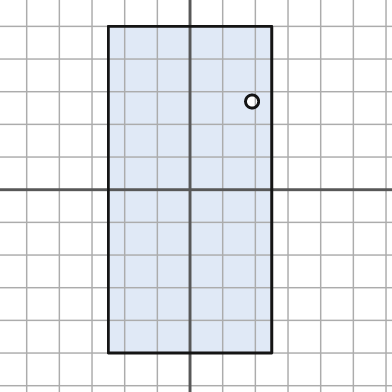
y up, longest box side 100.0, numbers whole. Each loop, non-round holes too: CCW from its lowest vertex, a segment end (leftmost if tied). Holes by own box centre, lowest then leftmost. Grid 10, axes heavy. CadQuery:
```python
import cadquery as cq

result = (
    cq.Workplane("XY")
    .moveTo(-25.0, -50.0)
    .lineTo(25.0, -50.0)
    .lineTo(25.0, 50.0)
    .lineTo(-25.0, 50.0)
    .close()
    .moveTo(19.0, 27.0)
    .circle(2.0)
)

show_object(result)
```